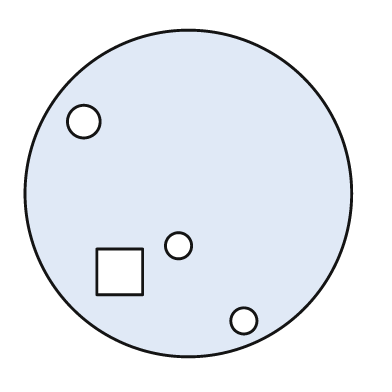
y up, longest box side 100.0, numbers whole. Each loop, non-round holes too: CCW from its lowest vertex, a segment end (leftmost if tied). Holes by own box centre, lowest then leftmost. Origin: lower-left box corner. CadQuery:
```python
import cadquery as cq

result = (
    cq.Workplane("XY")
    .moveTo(50.0, 50.0)
    .circle(50.0)
    .moveTo(67.0, 11.0)
    .circle(4.0)
    .moveTo(22.0, 19.0)
    .lineTo(36.0, 19.0)
    .lineTo(36.0, 33.0)
    .lineTo(22.0, 33.0)
    .close()
    .moveTo(47.0, 34.0)
    .circle(4.0)
    .moveTo(18.0, 72.0)
    .circle(5.0)
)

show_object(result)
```